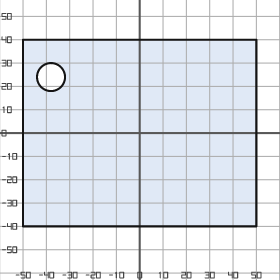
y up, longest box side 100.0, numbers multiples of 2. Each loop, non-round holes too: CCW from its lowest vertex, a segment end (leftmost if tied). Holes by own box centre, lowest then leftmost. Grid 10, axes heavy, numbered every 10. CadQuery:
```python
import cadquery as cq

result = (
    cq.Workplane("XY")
    .moveTo(-50.0, -40.0)
    .lineTo(50.0, -40.0)
    .lineTo(50.0, 40.0)
    .lineTo(-50.0, 40.0)
    .close()
    .moveTo(-38.0, 24.0)
    .circle(6.0)
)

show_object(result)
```